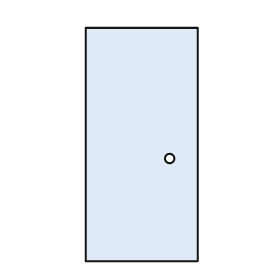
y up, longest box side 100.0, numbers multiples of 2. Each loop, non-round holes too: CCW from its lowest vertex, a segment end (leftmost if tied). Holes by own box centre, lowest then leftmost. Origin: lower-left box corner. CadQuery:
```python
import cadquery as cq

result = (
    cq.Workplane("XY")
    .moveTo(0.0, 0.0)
    .lineTo(48.0, 0.0)
    .lineTo(48.0, 100.0)
    .lineTo(0.0, 100.0)
    .close()
    .moveTo(36.0, 44.0)
    .circle(2.0)
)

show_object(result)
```